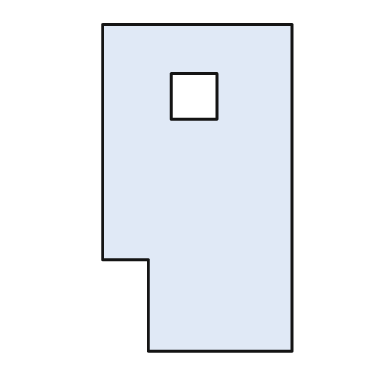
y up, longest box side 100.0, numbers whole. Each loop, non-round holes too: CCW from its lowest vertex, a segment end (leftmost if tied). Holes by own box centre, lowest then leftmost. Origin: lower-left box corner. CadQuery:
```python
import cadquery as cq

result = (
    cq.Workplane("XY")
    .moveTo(14.0, 0.0)
    .lineTo(58.0, 0.0)
    .lineTo(58.0, 100.0)
    .lineTo(0.0, 100.0)
    .lineTo(0.0, 28.0)
    .lineTo(14.0, 28.0)
    .close()
    .moveTo(21.0, 71.0)
    .lineTo(35.0, 71.0)
    .lineTo(35.0, 85.0)
    .lineTo(21.0, 85.0)
    .close()
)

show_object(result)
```